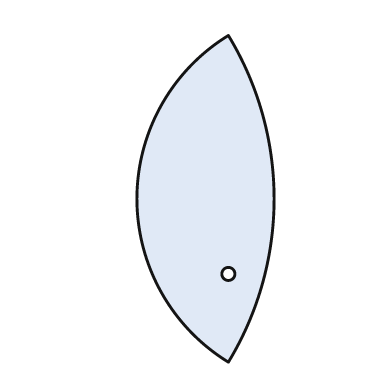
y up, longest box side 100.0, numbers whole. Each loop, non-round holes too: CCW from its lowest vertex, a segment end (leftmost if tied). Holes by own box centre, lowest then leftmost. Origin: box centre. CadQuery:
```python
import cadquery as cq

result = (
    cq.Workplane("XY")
    .moveTo(7.0, -50.0)
    .threePointArc((21.0, 0.0), (7.0, 50.0))
    .threePointArc((-21.0, 0.0), (7.0, -50.0))
    .close()
    .moveTo(7.0, -23.0)
    .circle(2.0)
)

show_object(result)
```